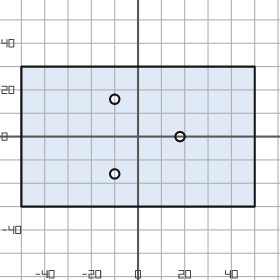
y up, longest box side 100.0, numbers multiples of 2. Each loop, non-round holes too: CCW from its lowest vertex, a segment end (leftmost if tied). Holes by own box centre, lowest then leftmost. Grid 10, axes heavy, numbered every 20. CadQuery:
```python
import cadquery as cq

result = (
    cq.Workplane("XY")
    .moveTo(-50.0, -30.0)
    .lineTo(50.0, -30.0)
    .lineTo(50.0, 30.0)
    .lineTo(-50.0, 30.0)
    .close()
    .moveTo(-10.0, -16.0)
    .circle(2.0)
    .moveTo(18.0, 0.0)
    .circle(2.0)
    .moveTo(-10.0, 16.0)
    .circle(2.0)
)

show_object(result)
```